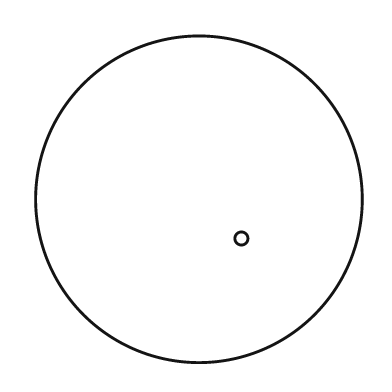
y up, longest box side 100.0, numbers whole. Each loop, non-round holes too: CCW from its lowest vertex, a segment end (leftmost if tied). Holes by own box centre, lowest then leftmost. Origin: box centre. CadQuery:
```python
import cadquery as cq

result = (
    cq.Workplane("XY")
    .moveTo(0.0, 0.0)
    .circle(50.0)
    .moveTo(13.0, -12.0)
    .circle(2.0)
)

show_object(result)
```